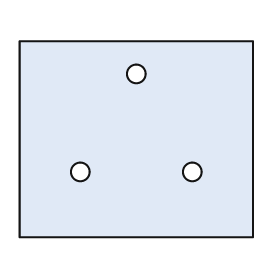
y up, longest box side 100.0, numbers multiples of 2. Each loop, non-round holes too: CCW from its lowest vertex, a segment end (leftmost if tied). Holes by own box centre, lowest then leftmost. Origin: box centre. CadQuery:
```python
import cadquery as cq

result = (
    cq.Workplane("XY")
    .moveTo(-50.0, -42.0)
    .lineTo(50.0, -42.0)
    .lineTo(50.0, 42.0)
    .lineTo(-50.0, 42.0)
    .close()
    .moveTo(-24.0, -14.0)
    .circle(4.0)
    .moveTo(24.0, -14.0)
    .circle(4.0)
    .moveTo(0.0, 28.0)
    .circle(4.0)
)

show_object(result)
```